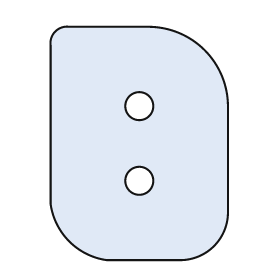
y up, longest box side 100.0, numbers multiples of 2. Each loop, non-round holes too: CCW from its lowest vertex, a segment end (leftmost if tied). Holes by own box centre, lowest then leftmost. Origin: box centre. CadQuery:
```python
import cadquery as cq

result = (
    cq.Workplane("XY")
    .moveTo(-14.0, -50.0)
    .lineTo(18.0, -50.0)
    .threePointArc((32.0, -44.0), (38.0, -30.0))
    .lineTo(38.0, 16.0)
    .threePointArc((28.0, 40.0), (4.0, 50.0))
    .lineTo(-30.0, 50.0)
    .threePointArc((-36.0, 48.0), (-38.0, 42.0))
    .lineTo(-38.0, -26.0)
    .threePointArc((-30.0, -42.0), (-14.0, -50.0))
    .close()
    .moveTo(0.0, -16.0)
    .circle(6.0)
    .moveTo(0.0, 16.0)
    .circle(6.0)
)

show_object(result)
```